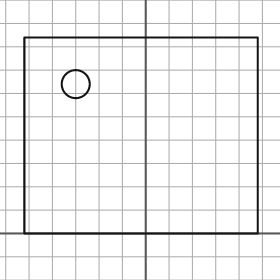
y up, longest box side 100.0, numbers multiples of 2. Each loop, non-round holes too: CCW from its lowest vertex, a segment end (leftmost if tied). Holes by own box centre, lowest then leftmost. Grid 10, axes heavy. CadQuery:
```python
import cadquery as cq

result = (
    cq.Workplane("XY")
    .moveTo(-52.0, 0.0)
    .lineTo(48.0, 0.0)
    .lineTo(48.0, 84.0)
    .lineTo(-52.0, 84.0)
    .close()
    .moveTo(-30.0, 64.0)
    .circle(6.0)
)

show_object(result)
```